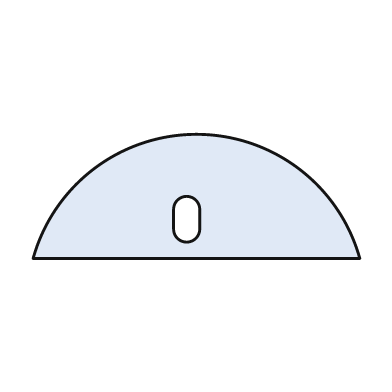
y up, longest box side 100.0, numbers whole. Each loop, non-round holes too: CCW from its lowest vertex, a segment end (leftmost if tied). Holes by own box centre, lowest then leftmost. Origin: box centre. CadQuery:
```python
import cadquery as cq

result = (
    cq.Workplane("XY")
    .moveTo(-50.0, -19.0)
    .lineTo(50.0, -19.0)
    .threePointArc((0.0, 19.0), (-50.0, -19.0))
    .close()
    .moveTo(-7.0, -10.0)
    .threePointArc((-3.0, -14.0), (1.0, -10.0))
    .lineTo(1.0, -4.0)
    .threePointArc((-3.0, 0.0), (-7.0, -4.0))
    .close()
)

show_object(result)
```